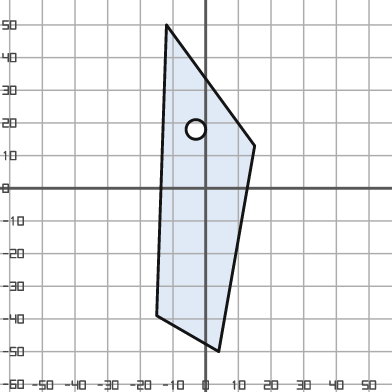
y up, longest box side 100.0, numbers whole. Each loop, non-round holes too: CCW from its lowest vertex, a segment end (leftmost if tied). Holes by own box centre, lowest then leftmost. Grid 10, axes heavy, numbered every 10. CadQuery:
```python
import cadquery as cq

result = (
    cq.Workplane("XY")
    .moveTo(4.0, -50.0)
    .lineTo(15.0, 13.0)
    .lineTo(-12.0, 50.0)
    .lineTo(-15.0, -39.0)
    .close()
    .moveTo(-3.0, 18.0)
    .circle(3.0)
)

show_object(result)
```